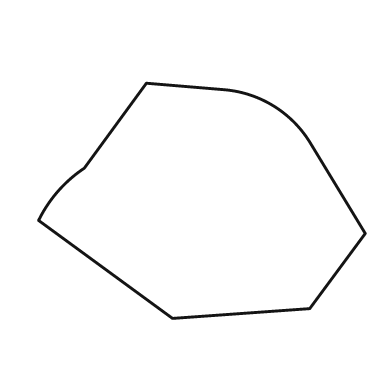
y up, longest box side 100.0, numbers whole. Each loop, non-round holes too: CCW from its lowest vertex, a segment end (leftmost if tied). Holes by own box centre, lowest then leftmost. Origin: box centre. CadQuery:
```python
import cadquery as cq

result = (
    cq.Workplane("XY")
    .moveTo(-9.0, -36.0)
    .lineTo(33.0, -33.0)
    .lineTo(50.0, -10.0)
    .lineTo(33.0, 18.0)
    .threePointArc((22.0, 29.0), (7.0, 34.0))
    .lineTo(-17.0, 36.0)
    .lineTo(-36.0, 10.0)
    .threePointArc((-44.0, 3.0), (-50.0, -6.0))
    .close()
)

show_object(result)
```